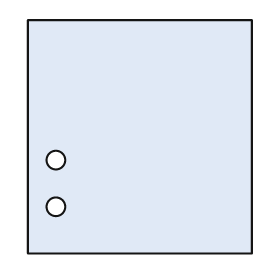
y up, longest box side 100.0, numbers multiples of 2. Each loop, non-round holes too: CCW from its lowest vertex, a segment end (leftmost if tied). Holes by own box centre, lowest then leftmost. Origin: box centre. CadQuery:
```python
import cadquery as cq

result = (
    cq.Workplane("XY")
    .moveTo(-48.0, -50.0)
    .lineTo(48.0, -50.0)
    .lineTo(48.0, 50.0)
    .lineTo(-48.0, 50.0)
    .close()
    .moveTo(-36.0, -30.0)
    .circle(4.0)
    .moveTo(-36.0, -10.0)
    .circle(4.0)
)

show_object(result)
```